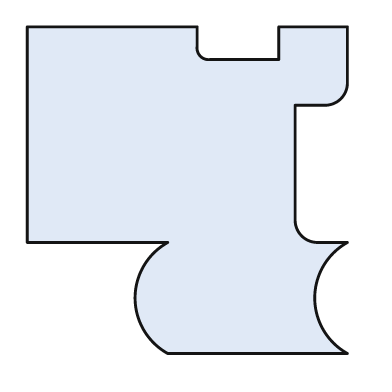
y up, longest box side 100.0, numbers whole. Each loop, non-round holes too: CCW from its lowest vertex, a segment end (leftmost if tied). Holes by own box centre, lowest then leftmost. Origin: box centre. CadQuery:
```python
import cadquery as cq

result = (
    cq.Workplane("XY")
    .moveTo(-6.0, -50.0)
    .lineTo(49.0, -50.0)
    .threePointArc((39.0, -33.0), (49.0, -16.0))
    .lineTo(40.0, -16.0)
    .threePointArc((35.0, -14.0), (33.0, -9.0))
    .lineTo(33.0, 26.0)
    .lineTo(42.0, 26.0)
    .threePointArc((47.0, 28.0), (49.0, 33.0))
    .lineTo(49.0, 50.0)
    .lineTo(28.0, 50.0)
    .lineTo(28.0, 40.0)
    .lineTo(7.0, 40.0)
    .threePointArc((4.0, 41.0), (3.0, 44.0))
    .lineTo(3.0, 50.0)
    .lineTo(-49.0, 50.0)
    .lineTo(-49.0, -16.0)
    .lineTo(-6.0, -16.0)
    .threePointArc((-16.0, -33.0), (-6.0, -50.0))
    .close()
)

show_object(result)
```